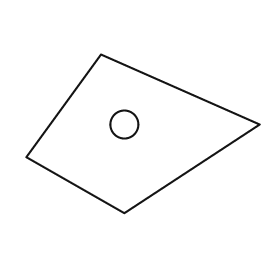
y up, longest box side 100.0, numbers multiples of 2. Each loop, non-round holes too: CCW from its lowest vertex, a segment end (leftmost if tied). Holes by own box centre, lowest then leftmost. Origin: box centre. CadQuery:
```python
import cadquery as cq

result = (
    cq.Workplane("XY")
    .moveTo(-8.0, -34.0)
    .lineTo(50.0, 4.0)
    .lineTo(-18.0, 34.0)
    .lineTo(-50.0, -10.0)
    .close()
    .moveTo(-8.0, 4.0)
    .circle(6.0)
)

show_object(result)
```